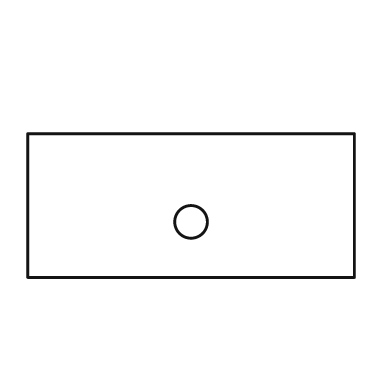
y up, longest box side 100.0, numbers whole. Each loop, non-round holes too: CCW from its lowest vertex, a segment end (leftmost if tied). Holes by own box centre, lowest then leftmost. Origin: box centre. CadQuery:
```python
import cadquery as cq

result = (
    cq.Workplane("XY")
    .moveTo(-50.0, -22.0)
    .lineTo(50.0, -22.0)
    .lineTo(50.0, 22.0)
    .lineTo(-50.0, 22.0)
    .close()
    .moveTo(0.0, -5.0)
    .circle(5.0)
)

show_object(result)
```